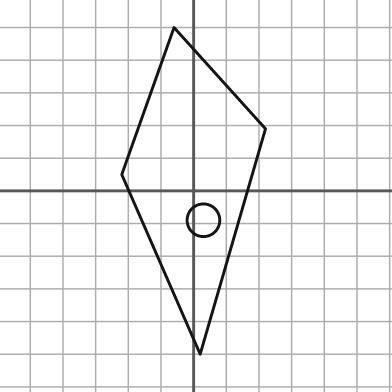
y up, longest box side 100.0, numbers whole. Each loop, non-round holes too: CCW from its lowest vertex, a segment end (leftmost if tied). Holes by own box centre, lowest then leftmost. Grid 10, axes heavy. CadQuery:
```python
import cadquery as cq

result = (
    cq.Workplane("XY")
    .moveTo(2.0, -50.0)
    .lineTo(22.0, 19.0)
    .lineTo(-6.0, 50.0)
    .lineTo(-22.0, 5.0)
    .close()
    .moveTo(3.0, -9.0)
    .circle(5.0)
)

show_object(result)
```